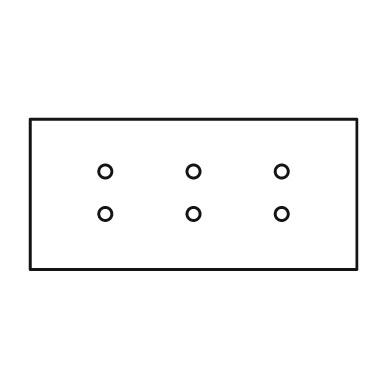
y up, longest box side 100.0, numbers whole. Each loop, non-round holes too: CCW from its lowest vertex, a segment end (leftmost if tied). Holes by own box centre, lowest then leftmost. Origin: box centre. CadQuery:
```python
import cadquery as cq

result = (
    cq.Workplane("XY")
    .moveTo(-50.0, -23.0)
    .lineTo(50.0, -23.0)
    .lineTo(50.0, 23.0)
    .lineTo(-50.0, 23.0)
    .close()
    .moveTo(-27.0, -6.0)
    .circle(2.0)
    .moveTo(0.0, -6.0)
    .circle(2.0)
    .moveTo(27.0, -6.0)
    .circle(2.0)
    .moveTo(-27.0, 7.0)
    .circle(2.0)
    .moveTo(0.0, 7.0)
    .circle(2.0)
    .moveTo(27.0, 7.0)
    .circle(2.0)
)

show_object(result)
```